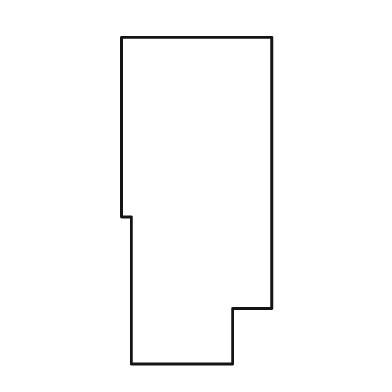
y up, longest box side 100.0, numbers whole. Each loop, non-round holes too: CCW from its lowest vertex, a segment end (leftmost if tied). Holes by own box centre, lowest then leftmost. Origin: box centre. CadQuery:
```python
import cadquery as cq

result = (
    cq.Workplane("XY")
    .moveTo(-20.0, -50.0)
    .lineTo(11.0, -50.0)
    .lineTo(11.0, -33.0)
    .lineTo(23.0, -33.0)
    .lineTo(23.0, 50.0)
    .lineTo(-23.0, 50.0)
    .lineTo(-23.0, -5.0)
    .lineTo(-20.0, -5.0)
    .close()
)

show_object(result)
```